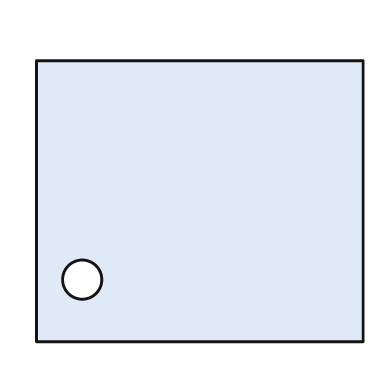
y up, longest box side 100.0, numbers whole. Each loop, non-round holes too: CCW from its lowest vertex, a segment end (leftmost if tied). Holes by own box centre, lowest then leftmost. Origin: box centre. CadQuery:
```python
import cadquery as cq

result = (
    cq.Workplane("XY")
    .moveTo(-50.0, -43.0)
    .lineTo(50.0, -43.0)
    .lineTo(50.0, 43.0)
    .lineTo(-50.0, 43.0)
    .close()
    .moveTo(-36.0, -24.0)
    .circle(6.0)
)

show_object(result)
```